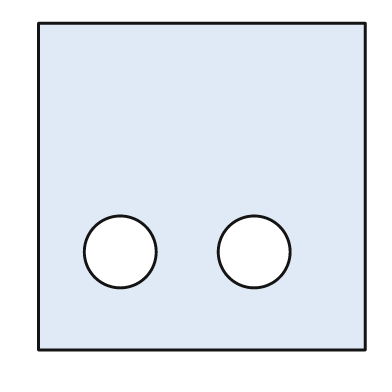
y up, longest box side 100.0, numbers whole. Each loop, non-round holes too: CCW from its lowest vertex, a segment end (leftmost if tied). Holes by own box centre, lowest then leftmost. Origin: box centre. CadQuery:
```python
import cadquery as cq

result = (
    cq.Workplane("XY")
    .moveTo(-50.0, -50.0)
    .lineTo(50.0, -50.0)
    .lineTo(50.0, 50.0)
    .lineTo(-50.0, 50.0)
    .close()
    .moveTo(-25.0, -20.0)
    .circle(11.0)
    .moveTo(16.0, -20.0)
    .circle(11.0)
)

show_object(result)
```